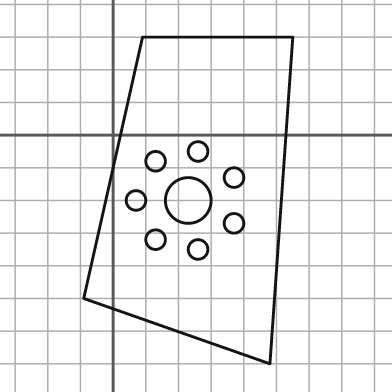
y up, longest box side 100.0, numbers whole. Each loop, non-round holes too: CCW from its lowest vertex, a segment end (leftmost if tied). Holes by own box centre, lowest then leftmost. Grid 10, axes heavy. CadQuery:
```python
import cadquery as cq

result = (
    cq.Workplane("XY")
    .moveTo(48.0, -70.0)
    .lineTo(55.0, 30.0)
    .lineTo(9.0, 30.0)
    .lineTo(-9.0, -50.0)
    .close()
    .moveTo(26.0, -35.0)
    .circle(3.0)
    .moveTo(13.0, -32.0)
    .circle(3.0)
    .moveTo(37.0, -27.0)
    .circle(3.0)
    .moveTo(7.0, -20.0)
    .circle(3.0)
    .moveTo(23.0, -20.0)
    .circle(7.0)
    .moveTo(37.0, -13.0)
    .circle(3.0)
    .moveTo(13.0, -8.0)
    .circle(3.0)
    .moveTo(26.0, -5.0)
    .circle(3.0)
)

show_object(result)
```